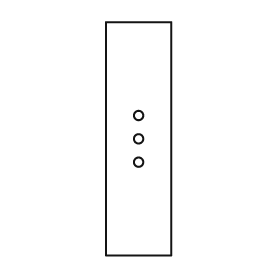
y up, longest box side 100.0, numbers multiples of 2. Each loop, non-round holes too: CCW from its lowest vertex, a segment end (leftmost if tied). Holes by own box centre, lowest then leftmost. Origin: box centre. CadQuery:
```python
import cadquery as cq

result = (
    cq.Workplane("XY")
    .moveTo(-14.0, -50.0)
    .lineTo(14.0, -50.0)
    .lineTo(14.0, 50.0)
    .lineTo(-14.0, 50.0)
    .close()
    .moveTo(0.0, -10.0)
    .circle(2.0)
    .moveTo(0.0, 0.0)
    .circle(2.0)
    .moveTo(0.0, 10.0)
    .circle(2.0)
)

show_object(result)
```